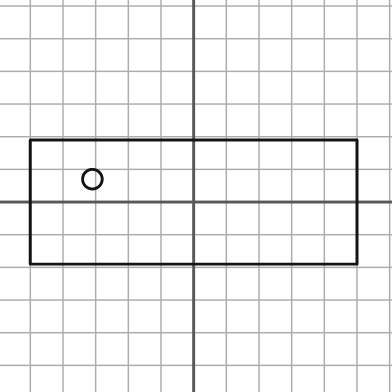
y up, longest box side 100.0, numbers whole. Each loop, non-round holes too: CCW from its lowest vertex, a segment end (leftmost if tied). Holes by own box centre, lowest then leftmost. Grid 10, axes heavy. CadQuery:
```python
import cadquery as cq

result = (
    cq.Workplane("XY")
    .moveTo(-50.0, -19.0)
    .lineTo(50.0, -19.0)
    .lineTo(50.0, 19.0)
    .lineTo(-50.0, 19.0)
    .close()
    .moveTo(-31.0, 7.0)
    .circle(3.0)
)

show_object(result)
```